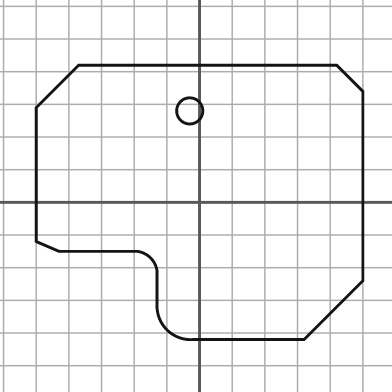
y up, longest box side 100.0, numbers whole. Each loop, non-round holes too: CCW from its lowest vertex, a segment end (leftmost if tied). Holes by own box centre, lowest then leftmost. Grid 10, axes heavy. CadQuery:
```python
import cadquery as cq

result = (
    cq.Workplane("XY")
    .moveTo(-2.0, -42.0)
    .lineTo(32.0, -42.0)
    .lineTo(50.0, -24.0)
    .lineTo(50.0, 34.0)
    .lineTo(42.0, 42.0)
    .lineTo(-37.0, 42.0)
    .lineTo(-50.0, 29.0)
    .lineTo(-50.0, -12.0)
    .lineTo(-43.0, -15.0)
    .lineTo(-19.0, -15.0)
    .threePointArc((-15.0, -17.0), (-13.0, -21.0))
    .lineTo(-13.0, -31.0)
    .threePointArc((-10.0, -39.0), (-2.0, -42.0))
    .close()
    .moveTo(-3.0, 28.0)
    .circle(4.0)
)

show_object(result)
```